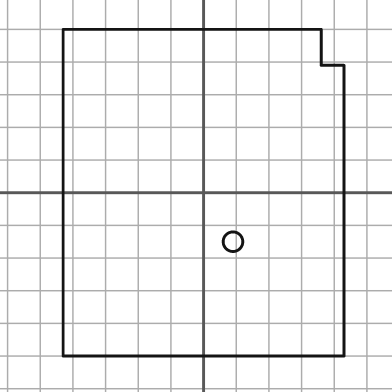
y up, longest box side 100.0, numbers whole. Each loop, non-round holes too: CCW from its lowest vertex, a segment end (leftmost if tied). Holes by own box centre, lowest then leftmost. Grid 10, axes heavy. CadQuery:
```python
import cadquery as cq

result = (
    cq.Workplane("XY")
    .moveTo(-43.0, -50.0)
    .lineTo(43.0, -50.0)
    .lineTo(43.0, 39.0)
    .lineTo(36.0, 39.0)
    .lineTo(36.0, 50.0)
    .lineTo(-43.0, 50.0)
    .close()
    .moveTo(9.0, -15.0)
    .circle(3.0)
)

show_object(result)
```